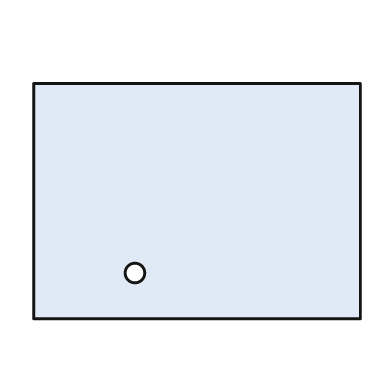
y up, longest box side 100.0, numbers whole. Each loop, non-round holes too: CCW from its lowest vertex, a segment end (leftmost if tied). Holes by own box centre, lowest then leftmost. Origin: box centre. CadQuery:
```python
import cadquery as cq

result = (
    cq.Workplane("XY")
    .moveTo(-50.0, -36.0)
    .lineTo(50.0, -36.0)
    .lineTo(50.0, 36.0)
    .lineTo(-50.0, 36.0)
    .close()
    .moveTo(-19.0, -22.0)
    .circle(3.0)
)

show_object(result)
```